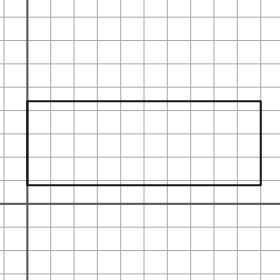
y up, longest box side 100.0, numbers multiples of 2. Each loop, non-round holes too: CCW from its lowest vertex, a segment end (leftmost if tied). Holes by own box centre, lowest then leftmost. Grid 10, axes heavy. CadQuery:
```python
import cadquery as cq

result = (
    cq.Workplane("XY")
    .moveTo(0.0, 8.0)
    .lineTo(100.0, 8.0)
    .lineTo(100.0, 44.0)
    .lineTo(0.0, 44.0)
    .close()
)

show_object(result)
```